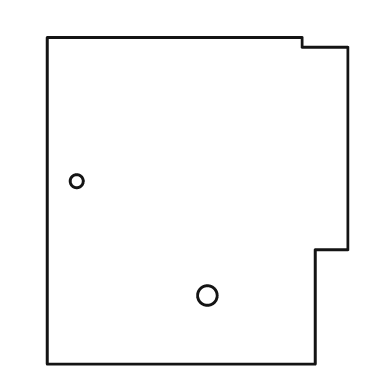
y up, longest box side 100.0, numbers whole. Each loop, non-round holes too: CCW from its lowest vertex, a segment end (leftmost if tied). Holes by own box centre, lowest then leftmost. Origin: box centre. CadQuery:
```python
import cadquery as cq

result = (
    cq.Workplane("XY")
    .moveTo(-46.0, -50.0)
    .lineTo(36.0, -50.0)
    .lineTo(36.0, -15.0)
    .lineTo(46.0, -15.0)
    .lineTo(46.0, 47.0)
    .lineTo(32.0, 47.0)
    .lineTo(32.0, 50.0)
    .lineTo(-46.0, 50.0)
    .close()
    .moveTo(3.0, -29.0)
    .circle(3.0)
    .moveTo(-37.0, 6.0)
    .circle(2.0)
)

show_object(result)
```